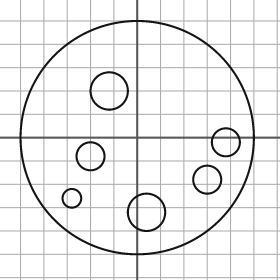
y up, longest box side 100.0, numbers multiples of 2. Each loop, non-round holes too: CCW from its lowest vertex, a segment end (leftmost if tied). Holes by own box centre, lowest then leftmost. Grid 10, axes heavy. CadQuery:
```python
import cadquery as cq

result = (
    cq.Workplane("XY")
    .moveTo(0.0, 0.0)
    .circle(50.0)
    .moveTo(4.0, -32.0)
    .circle(8.0)
    .moveTo(-28.0, -26.0)
    .circle(4.0)
    .moveTo(30.0, -18.0)
    .circle(6.0)
    .moveTo(-20.0, -8.0)
    .circle(6.0)
    .moveTo(38.0, -2.0)
    .circle(6.0)
    .moveTo(-12.0, 20.0)
    .circle(8.0)
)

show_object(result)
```